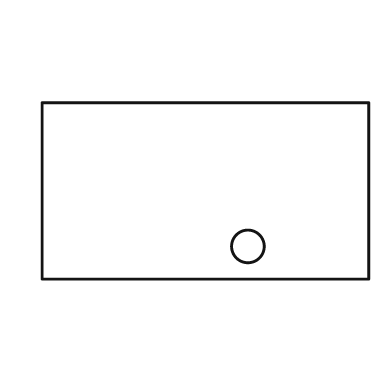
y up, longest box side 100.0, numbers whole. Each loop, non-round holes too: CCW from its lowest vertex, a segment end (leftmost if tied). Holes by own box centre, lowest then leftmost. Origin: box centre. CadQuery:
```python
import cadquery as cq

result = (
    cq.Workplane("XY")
    .moveTo(-50.0, -27.0)
    .lineTo(50.0, -27.0)
    .lineTo(50.0, 27.0)
    .lineTo(-50.0, 27.0)
    .close()
    .moveTo(13.0, -17.0)
    .circle(5.0)
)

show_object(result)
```